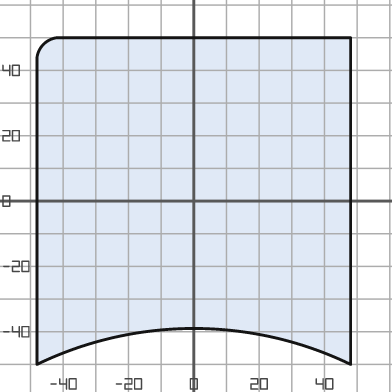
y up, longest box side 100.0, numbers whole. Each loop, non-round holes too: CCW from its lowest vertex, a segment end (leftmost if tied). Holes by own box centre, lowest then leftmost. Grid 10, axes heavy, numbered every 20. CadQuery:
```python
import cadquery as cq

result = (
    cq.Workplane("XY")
    .moveTo(-48.0, -50.0)
    .threePointArc((0.0, -39.0), (48.0, -50.0))
    .lineTo(48.0, 50.0)
    .lineTo(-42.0, 50.0)
    .threePointArc((-46.0, 48.0), (-48.0, 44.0))
    .close()
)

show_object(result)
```